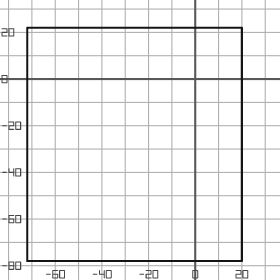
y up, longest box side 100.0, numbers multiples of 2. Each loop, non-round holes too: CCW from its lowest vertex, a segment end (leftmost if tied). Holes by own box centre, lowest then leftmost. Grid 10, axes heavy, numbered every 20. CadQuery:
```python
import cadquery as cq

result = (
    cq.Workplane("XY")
    .moveTo(-72.0, -78.0)
    .lineTo(20.0, -78.0)
    .lineTo(20.0, 22.0)
    .lineTo(-72.0, 22.0)
    .close()
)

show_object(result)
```